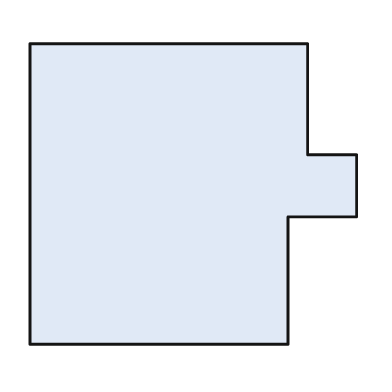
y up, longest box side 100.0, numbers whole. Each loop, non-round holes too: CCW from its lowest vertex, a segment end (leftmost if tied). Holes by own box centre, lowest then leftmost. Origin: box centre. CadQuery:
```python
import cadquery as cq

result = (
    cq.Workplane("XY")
    .moveTo(-50.0, -46.0)
    .lineTo(29.0, -46.0)
    .lineTo(29.0, -7.0)
    .lineTo(50.0, -7.0)
    .lineTo(50.0, 12.0)
    .lineTo(35.0, 12.0)
    .lineTo(35.0, 46.0)
    .lineTo(-50.0, 46.0)
    .close()
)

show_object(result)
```